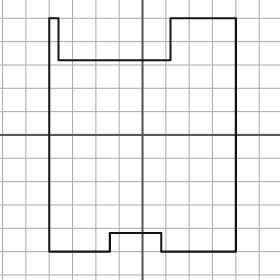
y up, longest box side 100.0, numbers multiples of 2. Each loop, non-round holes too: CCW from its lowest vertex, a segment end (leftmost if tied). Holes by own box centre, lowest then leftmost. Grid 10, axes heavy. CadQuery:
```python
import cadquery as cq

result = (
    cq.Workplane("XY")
    .moveTo(-40.0, -50.0)
    .lineTo(-14.0, -50.0)
    .lineTo(-14.0, -42.0)
    .lineTo(8.0, -42.0)
    .lineTo(8.0, -50.0)
    .lineTo(40.0, -50.0)
    .lineTo(40.0, 50.0)
    .lineTo(12.0, 50.0)
    .lineTo(12.0, 32.0)
    .lineTo(-36.0, 32.0)
    .lineTo(-36.0, 50.0)
    .lineTo(-40.0, 50.0)
    .close()
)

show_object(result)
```